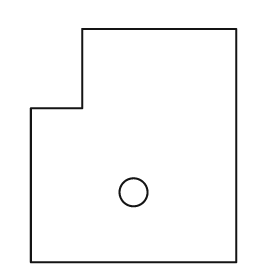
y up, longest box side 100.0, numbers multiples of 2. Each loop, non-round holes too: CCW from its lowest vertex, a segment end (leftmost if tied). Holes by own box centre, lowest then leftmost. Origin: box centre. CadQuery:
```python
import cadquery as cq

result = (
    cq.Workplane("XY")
    .moveTo(-44.0, -50.0)
    .lineTo(44.0, -50.0)
    .lineTo(44.0, 50.0)
    .lineTo(-22.0, 50.0)
    .lineTo(-22.0, 16.0)
    .lineTo(-44.0, 16.0)
    .close()
    .moveTo(0.0, -20.0)
    .circle(6.0)
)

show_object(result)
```